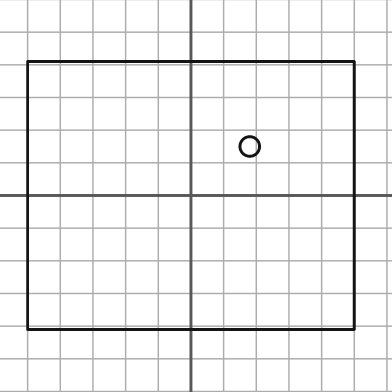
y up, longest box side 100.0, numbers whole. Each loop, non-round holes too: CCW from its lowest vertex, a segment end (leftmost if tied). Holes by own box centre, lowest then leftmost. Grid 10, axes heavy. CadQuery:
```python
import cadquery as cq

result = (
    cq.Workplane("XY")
    .moveTo(-50.0, -41.0)
    .lineTo(50.0, -41.0)
    .lineTo(50.0, 41.0)
    .lineTo(-50.0, 41.0)
    .close()
    .moveTo(18.0, 15.0)
    .circle(3.0)
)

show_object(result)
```